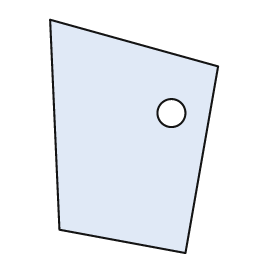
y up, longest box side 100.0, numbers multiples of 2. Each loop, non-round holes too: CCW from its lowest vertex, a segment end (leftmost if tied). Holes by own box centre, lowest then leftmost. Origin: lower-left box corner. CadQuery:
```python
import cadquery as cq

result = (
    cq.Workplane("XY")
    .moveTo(58.0, 0.0)
    .lineTo(72.0, 80.0)
    .lineTo(0.0, 100.0)
    .lineTo(4.0, 10.0)
    .close()
    .moveTo(52.0, 60.0)
    .circle(6.0)
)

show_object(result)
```